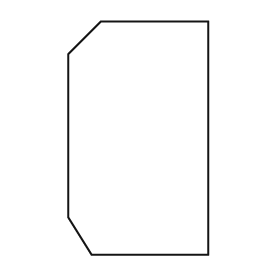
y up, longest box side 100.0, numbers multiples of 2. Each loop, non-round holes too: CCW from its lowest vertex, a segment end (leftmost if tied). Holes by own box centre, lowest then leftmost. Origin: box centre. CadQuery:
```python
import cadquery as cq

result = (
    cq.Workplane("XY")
    .moveTo(-20.0, -50.0)
    .lineTo(30.0, -50.0)
    .lineTo(30.0, 50.0)
    .lineTo(-16.0, 50.0)
    .lineTo(-30.0, 36.0)
    .lineTo(-30.0, -34.0)
    .close()
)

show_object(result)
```